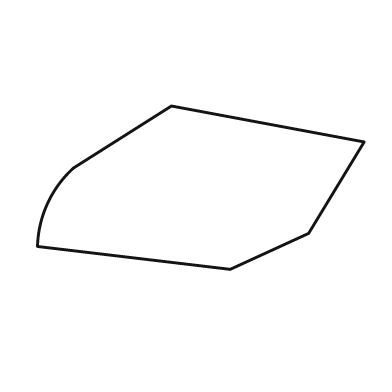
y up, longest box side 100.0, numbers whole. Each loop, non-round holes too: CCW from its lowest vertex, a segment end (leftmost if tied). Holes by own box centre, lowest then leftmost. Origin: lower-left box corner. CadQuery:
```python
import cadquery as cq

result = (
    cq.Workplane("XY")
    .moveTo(59.0, 0.0)
    .lineTo(83.0, 11.0)
    .lineTo(100.0, 39.0)
    .lineTo(41.0, 50.0)
    .lineTo(11.0, 31.0)
    .threePointArc((3.0, 20.0), (0.0, 7.0))
    .close()
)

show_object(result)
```